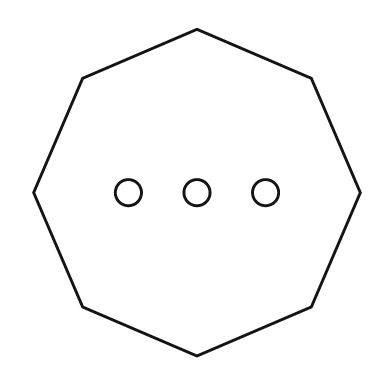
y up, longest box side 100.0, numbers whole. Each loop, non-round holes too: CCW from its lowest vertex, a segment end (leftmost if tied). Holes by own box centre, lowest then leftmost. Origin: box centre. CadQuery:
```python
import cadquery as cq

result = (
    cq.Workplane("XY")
    .moveTo(0.0, -50.0)
    .lineTo(35.0, -35.0)
    .lineTo(50.0, 0.0)
    .lineTo(35.0, 35.0)
    .lineTo(0.0, 50.0)
    .lineTo(-35.0, 35.0)
    .lineTo(-50.0, 0.0)
    .lineTo(-35.0, -35.0)
    .close()
    .moveTo(-21.0, 0.0)
    .circle(4.0)
    .moveTo(0.0, 0.0)
    .circle(4.0)
    .moveTo(21.0, 0.0)
    .circle(4.0)
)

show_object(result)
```